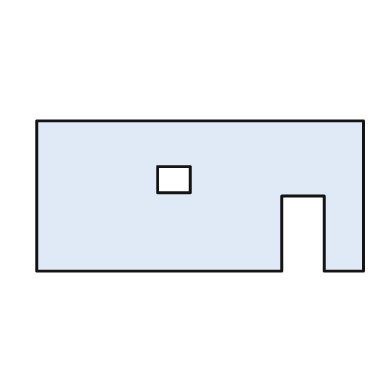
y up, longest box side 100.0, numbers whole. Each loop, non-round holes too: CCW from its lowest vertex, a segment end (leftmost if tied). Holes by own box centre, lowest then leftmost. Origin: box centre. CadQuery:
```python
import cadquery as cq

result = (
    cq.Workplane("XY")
    .moveTo(-50.0, -23.0)
    .lineTo(25.0, -23.0)
    .lineTo(25.0, 0.0)
    .lineTo(38.0, 0.0)
    .lineTo(38.0, -23.0)
    .lineTo(50.0, -23.0)
    .lineTo(50.0, 23.0)
    .lineTo(-50.0, 23.0)
    .close()
    .moveTo(-13.0, 1.0)
    .lineTo(-3.0, 1.0)
    .lineTo(-3.0, 9.0)
    .lineTo(-13.0, 9.0)
    .close()
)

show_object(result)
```